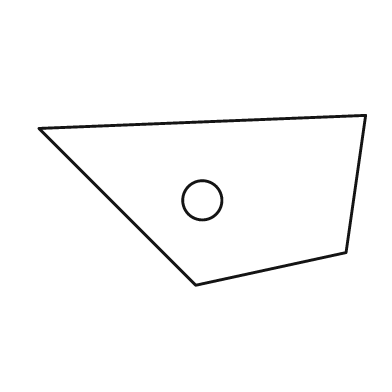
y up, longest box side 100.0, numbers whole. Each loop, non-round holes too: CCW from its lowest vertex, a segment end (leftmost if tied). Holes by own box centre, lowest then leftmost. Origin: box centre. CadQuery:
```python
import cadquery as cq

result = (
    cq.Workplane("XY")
    .moveTo(-2.0, -26.0)
    .lineTo(44.0, -16.0)
    .lineTo(50.0, 26.0)
    .lineTo(-50.0, 22.0)
    .close()
    .moveTo(0.0, 0.0)
    .circle(6.0)
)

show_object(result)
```